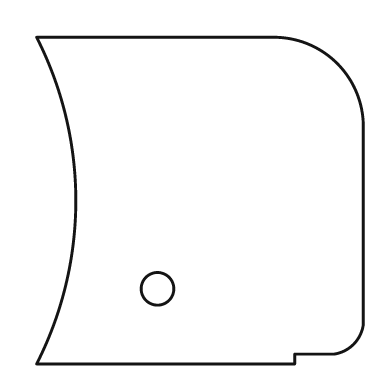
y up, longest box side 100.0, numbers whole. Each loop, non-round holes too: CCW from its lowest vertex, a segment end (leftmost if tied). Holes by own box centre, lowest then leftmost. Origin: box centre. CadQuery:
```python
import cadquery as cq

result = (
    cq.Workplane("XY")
    .moveTo(-50.0, -50.0)
    .lineTo(29.0, -50.0)
    .lineTo(29.0, -47.0)
    .lineTo(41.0, -47.0)
    .threePointArc((47.0, -44.0), (50.0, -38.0))
    .lineTo(50.0, 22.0)
    .threePointArc((42.0, 42.0), (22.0, 50.0))
    .lineTo(-50.0, 50.0)
    .threePointArc((-38.0, 0.0), (-50.0, -50.0))
    .close()
    .moveTo(-13.0, -27.0)
    .circle(5.0)
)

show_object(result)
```